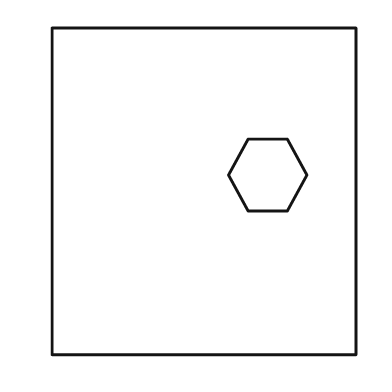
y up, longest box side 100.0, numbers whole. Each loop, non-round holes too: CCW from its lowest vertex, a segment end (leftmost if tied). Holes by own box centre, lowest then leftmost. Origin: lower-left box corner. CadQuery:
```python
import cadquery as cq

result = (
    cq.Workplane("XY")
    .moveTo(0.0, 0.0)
    .lineTo(93.0, 0.0)
    .lineTo(93.0, 100.0)
    .lineTo(0.0, 100.0)
    .close()
    .moveTo(60.0, 44.0)
    .lineTo(72.0, 44.0)
    .lineTo(78.0, 55.0)
    .lineTo(72.0, 66.0)
    .lineTo(60.0, 66.0)
    .lineTo(54.0, 55.0)
    .close()
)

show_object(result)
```